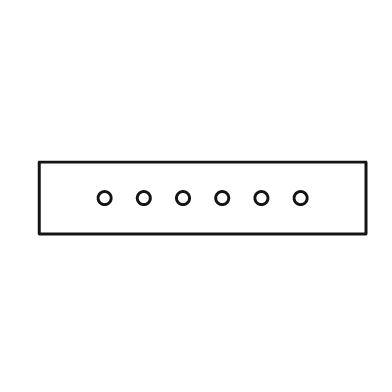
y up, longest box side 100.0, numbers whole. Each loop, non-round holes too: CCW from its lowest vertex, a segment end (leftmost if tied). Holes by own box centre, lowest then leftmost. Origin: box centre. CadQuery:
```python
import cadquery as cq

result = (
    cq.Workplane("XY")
    .moveTo(-50.0, -11.0)
    .lineTo(50.0, -11.0)
    .lineTo(50.0, 11.0)
    .lineTo(-50.0, 11.0)
    .close()
    .moveTo(-30.0, 0.0)
    .circle(2.0)
    .moveTo(-18.0, 0.0)
    .circle(2.0)
    .moveTo(-6.0, 0.0)
    .circle(2.0)
    .moveTo(6.0, 0.0)
    .circle(2.0)
    .moveTo(18.0, 0.0)
    .circle(2.0)
    .moveTo(30.0, 0.0)
    .circle(2.0)
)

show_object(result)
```